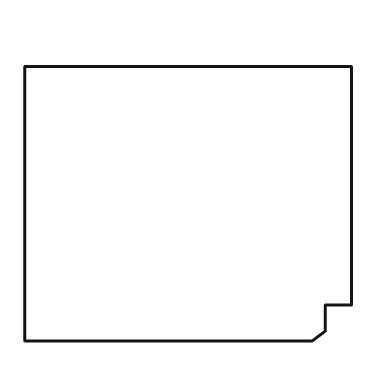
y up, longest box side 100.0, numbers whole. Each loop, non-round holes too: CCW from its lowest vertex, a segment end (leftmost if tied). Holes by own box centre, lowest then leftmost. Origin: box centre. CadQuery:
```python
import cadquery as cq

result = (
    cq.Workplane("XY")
    .moveTo(-50.0, -42.0)
    .lineTo(38.0, -42.0)
    .lineTo(42.0, -39.0)
    .lineTo(42.0, -31.0)
    .lineTo(50.0, -31.0)
    .lineTo(50.0, 42.0)
    .lineTo(-50.0, 42.0)
    .close()
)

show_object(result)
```